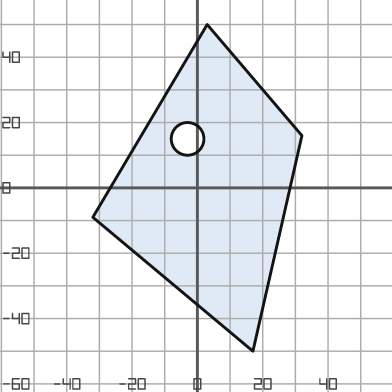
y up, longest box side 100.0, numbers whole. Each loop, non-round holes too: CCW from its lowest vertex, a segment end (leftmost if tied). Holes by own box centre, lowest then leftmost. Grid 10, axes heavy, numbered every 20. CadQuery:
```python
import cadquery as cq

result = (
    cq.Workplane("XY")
    .moveTo(17.0, -50.0)
    .lineTo(32.0, 16.0)
    .lineTo(3.0, 50.0)
    .lineTo(-32.0, -9.0)
    .close()
    .moveTo(-3.0, 15.0)
    .circle(5.0)
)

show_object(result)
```